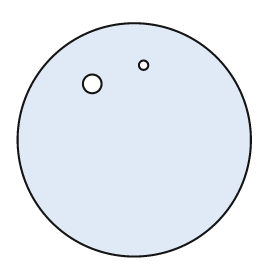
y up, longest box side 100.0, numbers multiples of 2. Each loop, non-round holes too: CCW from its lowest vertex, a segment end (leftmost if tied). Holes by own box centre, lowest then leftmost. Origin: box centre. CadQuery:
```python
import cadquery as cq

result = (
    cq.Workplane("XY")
    .moveTo(0.0, 0.0)
    .circle(50.0)
    .moveTo(-18.0, 24.0)
    .circle(4.0)
    .moveTo(4.0, 32.0)
    .circle(2.0)
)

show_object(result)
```